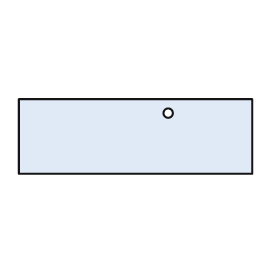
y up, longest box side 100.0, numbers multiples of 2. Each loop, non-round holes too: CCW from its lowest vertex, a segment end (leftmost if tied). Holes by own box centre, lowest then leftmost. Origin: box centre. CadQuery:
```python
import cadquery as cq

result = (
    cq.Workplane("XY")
    .moveTo(-50.0, -16.0)
    .lineTo(50.0, -16.0)
    .lineTo(50.0, 16.0)
    .lineTo(-50.0, 16.0)
    .close()
    .moveTo(14.0, 10.0)
    .circle(2.0)
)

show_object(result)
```